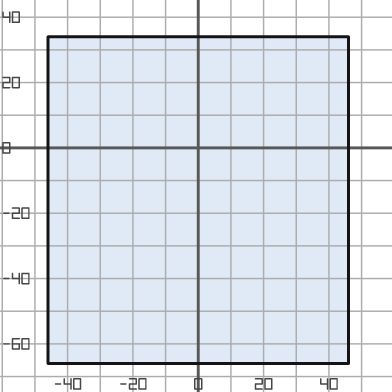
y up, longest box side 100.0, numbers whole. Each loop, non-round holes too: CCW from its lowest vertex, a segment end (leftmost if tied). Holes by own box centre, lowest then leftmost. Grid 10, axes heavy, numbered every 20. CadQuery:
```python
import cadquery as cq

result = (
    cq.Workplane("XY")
    .moveTo(-46.0, -66.0)
    .lineTo(46.0, -66.0)
    .lineTo(46.0, 34.0)
    .lineTo(-46.0, 34.0)
    .close()
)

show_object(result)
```